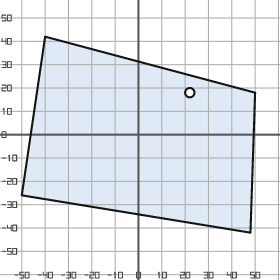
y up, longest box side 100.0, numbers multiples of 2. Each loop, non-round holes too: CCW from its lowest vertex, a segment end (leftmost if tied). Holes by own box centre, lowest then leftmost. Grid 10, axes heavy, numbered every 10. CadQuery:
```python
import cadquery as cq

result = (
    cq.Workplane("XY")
    .moveTo(48.0, -42.0)
    .lineTo(50.0, 18.0)
    .lineTo(-40.0, 42.0)
    .lineTo(-50.0, -26.0)
    .close()
    .moveTo(22.0, 18.0)
    .circle(2.0)
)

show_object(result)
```